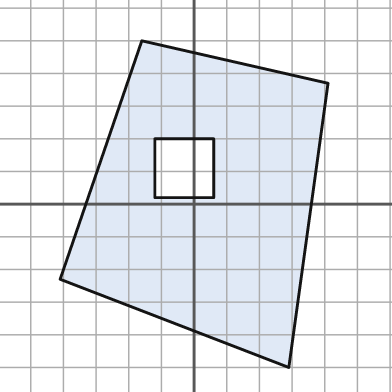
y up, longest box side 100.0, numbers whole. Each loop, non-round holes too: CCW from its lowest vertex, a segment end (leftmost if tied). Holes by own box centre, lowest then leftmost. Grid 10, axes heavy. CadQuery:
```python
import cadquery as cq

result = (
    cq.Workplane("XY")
    .moveTo(29.0, -50.0)
    .lineTo(41.0, 37.0)
    .lineTo(-16.0, 50.0)
    .lineTo(-41.0, -23.0)
    .close()
    .moveTo(-12.0, 2.0)
    .lineTo(6.0, 2.0)
    .lineTo(6.0, 20.0)
    .lineTo(-12.0, 20.0)
    .close()
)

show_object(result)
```